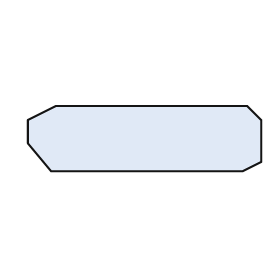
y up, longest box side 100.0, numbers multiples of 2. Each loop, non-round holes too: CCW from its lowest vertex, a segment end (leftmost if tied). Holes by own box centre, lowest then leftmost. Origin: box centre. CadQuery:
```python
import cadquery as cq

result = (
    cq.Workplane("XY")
    .moveTo(-40.0, -14.0)
    .lineTo(42.0, -14.0)
    .lineTo(50.0, -10.0)
    .lineTo(50.0, 8.0)
    .lineTo(44.0, 14.0)
    .lineTo(-38.0, 14.0)
    .lineTo(-50.0, 8.0)
    .lineTo(-50.0, -2.0)
    .close()
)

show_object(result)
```